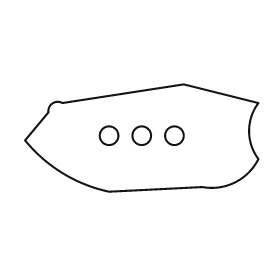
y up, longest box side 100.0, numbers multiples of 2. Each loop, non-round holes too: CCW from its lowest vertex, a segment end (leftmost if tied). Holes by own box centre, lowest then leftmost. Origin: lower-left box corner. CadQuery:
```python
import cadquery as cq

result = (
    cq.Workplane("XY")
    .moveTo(36.0, 0.0)
    .lineTo(76.0, 2.0)
    .threePointArc((90.0, 4.0), (100.0, 14.0))
    .threePointArc((96.0, 26.0), (100.0, 38.0))
    .lineTo(68.0, 46.0)
    .lineTo(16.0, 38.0)
    .threePointArc((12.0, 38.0), (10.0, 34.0))
    .lineTo(0.0, 22.0)
    .threePointArc((16.0, 8.0), (36.0, 0.0))
    .close()
    .moveTo(36.0, 24.0)
    .circle(4.0)
    .moveTo(50.0, 24.0)
    .circle(4.0)
    .moveTo(64.0, 24.0)
    .circle(4.0)
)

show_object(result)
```